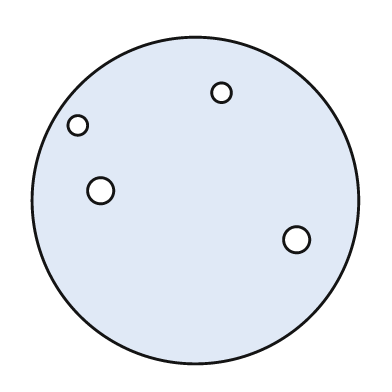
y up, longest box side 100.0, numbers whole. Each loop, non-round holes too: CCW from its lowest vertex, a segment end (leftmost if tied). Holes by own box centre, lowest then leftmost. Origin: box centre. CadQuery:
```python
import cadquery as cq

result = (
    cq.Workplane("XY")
    .moveTo(0.0, 0.0)
    .circle(50.0)
    .moveTo(31.0, -12.0)
    .circle(4.0)
    .moveTo(-29.0, 3.0)
    .circle(4.0)
    .moveTo(-36.0, 23.0)
    .circle(3.0)
    .moveTo(8.0, 33.0)
    .circle(3.0)
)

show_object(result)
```